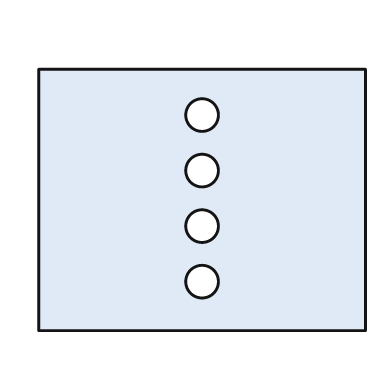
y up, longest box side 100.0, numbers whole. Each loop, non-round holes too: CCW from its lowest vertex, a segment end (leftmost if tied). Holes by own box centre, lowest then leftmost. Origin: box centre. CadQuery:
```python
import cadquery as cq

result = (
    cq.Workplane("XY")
    .moveTo(-50.0, -40.0)
    .lineTo(50.0, -40.0)
    .lineTo(50.0, 40.0)
    .lineTo(-50.0, 40.0)
    .close()
    .moveTo(0.0, -25.0)
    .circle(5.0)
    .moveTo(0.0, -8.0)
    .circle(5.0)
    .moveTo(0.0, 9.0)
    .circle(5.0)
    .moveTo(0.0, 26.0)
    .circle(5.0)
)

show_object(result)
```